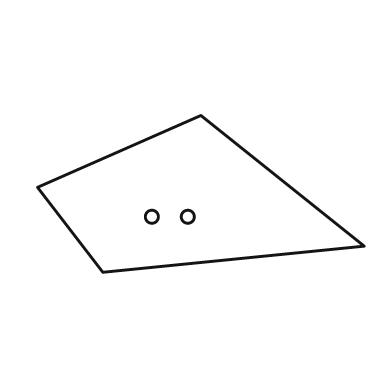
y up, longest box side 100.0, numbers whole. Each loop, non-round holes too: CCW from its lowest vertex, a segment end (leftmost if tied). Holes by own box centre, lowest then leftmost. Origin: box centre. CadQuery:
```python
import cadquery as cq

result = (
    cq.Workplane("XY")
    .moveTo(-30.0, -24.0)
    .lineTo(50.0, -16.0)
    .lineTo(0.0, 24.0)
    .lineTo(-50.0, 2.0)
    .close()
    .moveTo(-15.0, -7.0)
    .circle(2.0)
    .moveTo(-4.0, -7.0)
    .circle(2.0)
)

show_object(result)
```